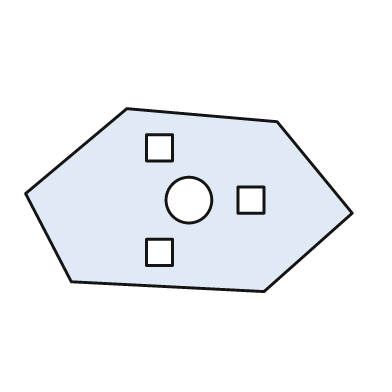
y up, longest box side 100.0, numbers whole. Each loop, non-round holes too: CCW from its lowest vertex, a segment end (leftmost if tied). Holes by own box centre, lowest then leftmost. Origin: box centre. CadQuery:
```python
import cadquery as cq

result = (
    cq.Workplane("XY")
    .moveTo(23.0, -28.0)
    .lineTo(50.0, -4.0)
    .lineTo(27.0, 24.0)
    .lineTo(-19.0, 28.0)
    .lineTo(-50.0, 2.0)
    .lineTo(-36.0, -25.0)
    .close()
    .moveTo(-13.0, -20.0)
    .lineTo(-5.0, -20.0)
    .lineTo(-5.0, -12.0)
    .lineTo(-13.0, -12.0)
    .close()
    .moveTo(0.0, 0.0)
    .circle(7.0)
    .moveTo(15.0, -4.0)
    .lineTo(23.0, -4.0)
    .lineTo(23.0, 4.0)
    .lineTo(15.0, 4.0)
    .close()
    .moveTo(-13.0, 12.0)
    .lineTo(-5.0, 12.0)
    .lineTo(-5.0, 20.0)
    .lineTo(-13.0, 20.0)
    .close()
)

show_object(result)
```